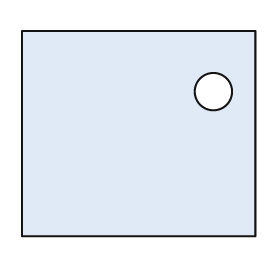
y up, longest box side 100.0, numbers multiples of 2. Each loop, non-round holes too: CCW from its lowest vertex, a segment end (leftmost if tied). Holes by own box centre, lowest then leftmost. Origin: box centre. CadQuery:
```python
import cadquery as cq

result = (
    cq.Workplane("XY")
    .moveTo(-50.0, -44.0)
    .lineTo(50.0, -44.0)
    .lineTo(50.0, 44.0)
    .lineTo(-50.0, 44.0)
    .close()
    .moveTo(32.0, 18.0)
    .circle(8.0)
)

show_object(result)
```